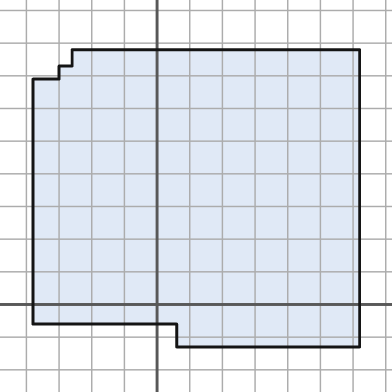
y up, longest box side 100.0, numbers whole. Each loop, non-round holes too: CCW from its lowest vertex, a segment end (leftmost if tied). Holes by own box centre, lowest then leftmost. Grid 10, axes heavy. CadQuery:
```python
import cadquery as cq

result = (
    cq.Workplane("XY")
    .moveTo(6.0, -13.0)
    .lineTo(62.0, -13.0)
    .lineTo(62.0, 78.0)
    .lineTo(-26.0, 78.0)
    .lineTo(-26.0, 73.0)
    .lineTo(-30.0, 73.0)
    .lineTo(-30.0, 69.0)
    .lineTo(-38.0, 69.0)
    .lineTo(-38.0, -6.0)
    .lineTo(6.0, -6.0)
    .close()
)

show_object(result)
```